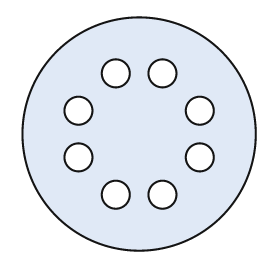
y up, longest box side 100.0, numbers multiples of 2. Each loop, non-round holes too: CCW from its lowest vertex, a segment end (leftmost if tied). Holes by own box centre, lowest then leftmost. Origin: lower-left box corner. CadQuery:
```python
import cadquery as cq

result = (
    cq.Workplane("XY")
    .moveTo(50.0, 50.0)
    .circle(50.0)
    .moveTo(40.0, 24.0)
    .circle(6.0)
    .moveTo(60.0, 24.0)
    .circle(6.0)
    .moveTo(24.0, 40.0)
    .circle(6.0)
    .moveTo(76.0, 40.0)
    .circle(6.0)
    .moveTo(24.0, 60.0)
    .circle(6.0)
    .moveTo(76.0, 60.0)
    .circle(6.0)
    .moveTo(40.0, 76.0)
    .circle(6.0)
    .moveTo(60.0, 76.0)
    .circle(6.0)
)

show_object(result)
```